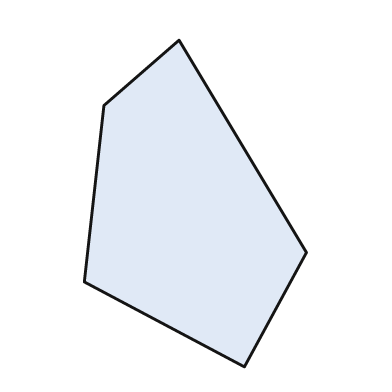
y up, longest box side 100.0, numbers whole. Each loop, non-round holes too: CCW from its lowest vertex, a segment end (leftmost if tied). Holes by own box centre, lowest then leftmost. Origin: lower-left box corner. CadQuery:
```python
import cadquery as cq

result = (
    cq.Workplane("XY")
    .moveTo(49.0, 0.0)
    .lineTo(68.0, 35.0)
    .lineTo(29.0, 100.0)
    .lineTo(6.0, 80.0)
    .lineTo(0.0, 26.0)
    .close()
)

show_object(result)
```